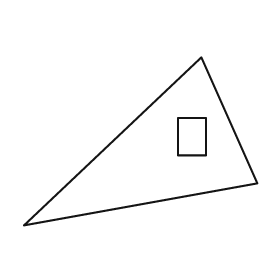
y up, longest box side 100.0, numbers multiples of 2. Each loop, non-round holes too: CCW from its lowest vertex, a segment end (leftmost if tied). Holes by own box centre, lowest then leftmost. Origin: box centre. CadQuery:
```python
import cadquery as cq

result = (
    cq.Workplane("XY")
    .moveTo(-50.0, -36.0)
    .lineTo(50.0, -18.0)
    .lineTo(26.0, 36.0)
    .close()
    .moveTo(16.0, -6.0)
    .lineTo(28.0, -6.0)
    .lineTo(28.0, 10.0)
    .lineTo(16.0, 10.0)
    .close()
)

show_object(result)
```